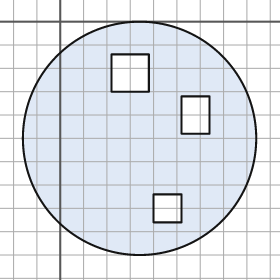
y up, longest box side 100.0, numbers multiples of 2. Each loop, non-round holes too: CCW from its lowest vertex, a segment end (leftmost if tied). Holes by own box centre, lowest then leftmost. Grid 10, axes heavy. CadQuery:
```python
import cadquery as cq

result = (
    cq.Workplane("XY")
    .moveTo(34.0, -50.0)
    .circle(50.0)
    .moveTo(40.0, -86.0)
    .lineTo(52.0, -86.0)
    .lineTo(52.0, -74.0)
    .lineTo(40.0, -74.0)
    .close()
    .moveTo(52.0, -48.0)
    .lineTo(64.0, -48.0)
    .lineTo(64.0, -32.0)
    .lineTo(52.0, -32.0)
    .close()
    .moveTo(22.0, -30.0)
    .lineTo(38.0, -30.0)
    .lineTo(38.0, -14.0)
    .lineTo(22.0, -14.0)
    .close()
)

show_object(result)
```